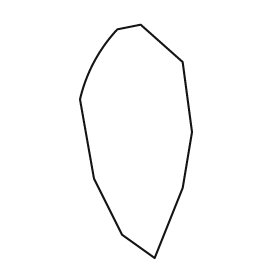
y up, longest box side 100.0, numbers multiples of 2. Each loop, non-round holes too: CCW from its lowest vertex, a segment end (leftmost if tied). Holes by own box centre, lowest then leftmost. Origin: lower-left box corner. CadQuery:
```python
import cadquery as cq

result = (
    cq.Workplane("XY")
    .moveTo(32.0, 0.0)
    .lineTo(44.0, 30.0)
    .lineTo(48.0, 54.0)
    .lineTo(44.0, 84.0)
    .lineTo(26.0, 100.0)
    .lineTo(16.0, 98.0)
    .threePointArc((6.0, 84.0), (0.0, 68.0))
    .lineTo(6.0, 34.0)
    .lineTo(18.0, 10.0)
    .close()
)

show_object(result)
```